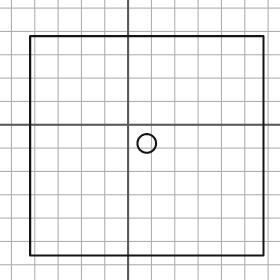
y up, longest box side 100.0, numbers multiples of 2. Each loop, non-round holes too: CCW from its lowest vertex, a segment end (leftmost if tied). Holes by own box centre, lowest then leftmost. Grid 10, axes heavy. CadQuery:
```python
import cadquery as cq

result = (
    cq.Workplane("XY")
    .moveTo(-42.0, -56.0)
    .lineTo(58.0, -56.0)
    .lineTo(58.0, 38.0)
    .lineTo(-42.0, 38.0)
    .close()
    .moveTo(8.0, -8.0)
    .circle(4.0)
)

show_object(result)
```